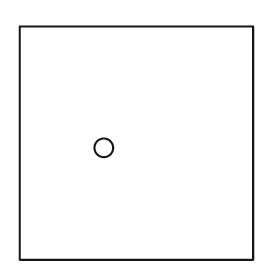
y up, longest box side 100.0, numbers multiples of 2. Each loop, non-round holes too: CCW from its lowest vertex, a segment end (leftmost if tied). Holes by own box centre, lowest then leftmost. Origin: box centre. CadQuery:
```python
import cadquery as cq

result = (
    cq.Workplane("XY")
    .moveTo(-50.0, -50.0)
    .lineTo(50.0, -50.0)
    .lineTo(50.0, 50.0)
    .lineTo(-50.0, 50.0)
    .close()
    .moveTo(-14.0, -2.0)
    .circle(4.0)
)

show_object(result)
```